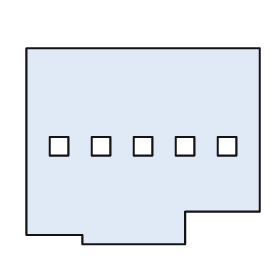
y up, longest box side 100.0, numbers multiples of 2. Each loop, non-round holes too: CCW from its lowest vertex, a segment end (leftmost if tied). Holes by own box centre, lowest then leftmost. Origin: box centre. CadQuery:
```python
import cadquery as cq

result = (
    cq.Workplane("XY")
    .moveTo(-26.0, -42.0)
    .lineTo(18.0, -42.0)
    .lineTo(18.0, -28.0)
    .lineTo(50.0, -28.0)
    .lineTo(50.0, 42.0)
    .lineTo(-50.0, 42.0)
    .lineTo(-50.0, -38.0)
    .lineTo(-26.0, -38.0)
    .close()
    .moveTo(-40.0, -4.0)
    .lineTo(-32.0, -4.0)
    .lineTo(-32.0, 4.0)
    .lineTo(-40.0, 4.0)
    .close()
    .moveTo(-22.0, -4.0)
    .lineTo(-14.0, -4.0)
    .lineTo(-14.0, 4.0)
    .lineTo(-22.0, 4.0)
    .close()
    .moveTo(-4.0, -4.0)
    .lineTo(4.0, -4.0)
    .lineTo(4.0, 4.0)
    .lineTo(-4.0, 4.0)
    .close()
    .moveTo(14.0, -4.0)
    .lineTo(22.0, -4.0)
    .lineTo(22.0, 4.0)
    .lineTo(14.0, 4.0)
    .close()
    .moveTo(32.0, -4.0)
    .lineTo(40.0, -4.0)
    .lineTo(40.0, 4.0)
    .lineTo(32.0, 4.0)
    .close()
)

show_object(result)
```